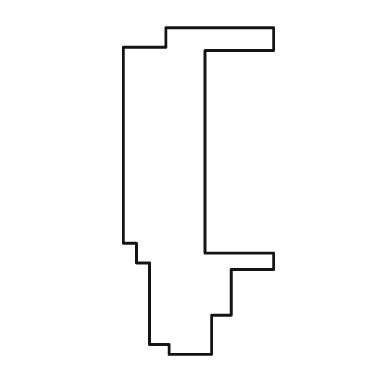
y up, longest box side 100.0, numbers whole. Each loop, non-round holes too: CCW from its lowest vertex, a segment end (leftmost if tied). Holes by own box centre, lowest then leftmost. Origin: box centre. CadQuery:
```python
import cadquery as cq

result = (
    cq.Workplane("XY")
    .moveTo(-9.0, -50.0)
    .lineTo(4.0, -50.0)
    .lineTo(4.0, -38.0)
    .lineTo(10.0, -38.0)
    .lineTo(10.0, -24.0)
    .lineTo(23.0, -24.0)
    .lineTo(23.0, -19.0)
    .lineTo(2.0, -19.0)
    .lineTo(2.0, 43.0)
    .lineTo(23.0, 43.0)
    .lineTo(23.0, 50.0)
    .lineTo(-10.0, 50.0)
    .lineTo(-10.0, 44.0)
    .lineTo(-23.0, 44.0)
    .lineTo(-23.0, -16.0)
    .lineTo(-19.0, -16.0)
    .lineTo(-19.0, -22.0)
    .lineTo(-15.0, -22.0)
    .lineTo(-15.0, -47.0)
    .lineTo(-9.0, -47.0)
    .close()
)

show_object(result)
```